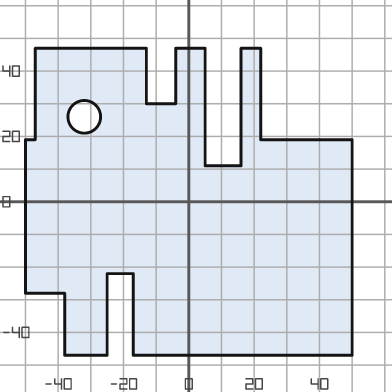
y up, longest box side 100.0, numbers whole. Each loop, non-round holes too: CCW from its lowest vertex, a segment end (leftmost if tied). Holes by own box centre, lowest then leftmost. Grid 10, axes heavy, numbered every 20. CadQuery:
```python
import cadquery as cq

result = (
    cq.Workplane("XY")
    .moveTo(-38.0, -47.0)
    .lineTo(-25.0, -47.0)
    .lineTo(-25.0, -22.0)
    .lineTo(-17.0, -22.0)
    .lineTo(-17.0, -47.0)
    .lineTo(50.0, -47.0)
    .lineTo(50.0, 19.0)
    .lineTo(22.0, 19.0)
    .lineTo(22.0, 47.0)
    .lineTo(16.0, 47.0)
    .lineTo(16.0, 11.0)
    .lineTo(5.0, 11.0)
    .lineTo(5.0, 47.0)
    .lineTo(-4.0, 47.0)
    .lineTo(-4.0, 30.0)
    .lineTo(-13.0, 30.0)
    .lineTo(-13.0, 47.0)
    .lineTo(-47.0, 47.0)
    .lineTo(-47.0, 19.0)
    .lineTo(-50.0, 19.0)
    .lineTo(-50.0, -28.0)
    .lineTo(-38.0, -28.0)
    .close()
    .moveTo(-32.0, 26.0)
    .circle(5.0)
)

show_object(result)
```